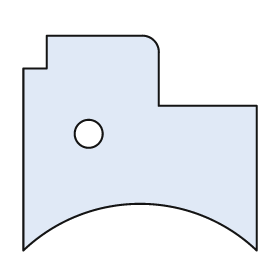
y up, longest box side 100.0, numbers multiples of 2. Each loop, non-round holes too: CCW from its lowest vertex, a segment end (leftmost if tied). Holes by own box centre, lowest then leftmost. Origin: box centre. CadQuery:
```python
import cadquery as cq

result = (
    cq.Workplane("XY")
    .moveTo(-50.0, -46.0)
    .threePointArc((0.0, -26.0), (50.0, -46.0))
    .lineTo(50.0, 16.0)
    .lineTo(8.0, 16.0)
    .lineTo(8.0, 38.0)
    .threePointArc((6.0, 44.0), (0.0, 46.0))
    .lineTo(-40.0, 46.0)
    .lineTo(-40.0, 32.0)
    .lineTo(-50.0, 32.0)
    .close()
    .moveTo(-22.0, 4.0)
    .circle(6.0)
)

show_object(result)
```